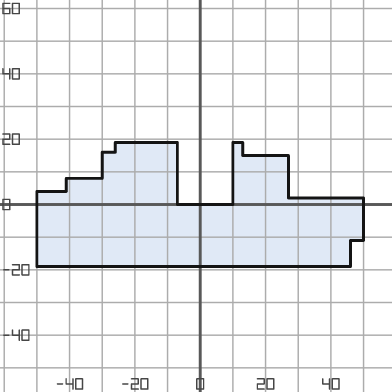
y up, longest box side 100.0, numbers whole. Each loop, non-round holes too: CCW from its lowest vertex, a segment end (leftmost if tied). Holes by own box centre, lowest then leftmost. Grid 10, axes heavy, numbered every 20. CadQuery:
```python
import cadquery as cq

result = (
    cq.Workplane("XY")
    .moveTo(-50.0, -19.0)
    .lineTo(46.0, -19.0)
    .lineTo(46.0, -11.0)
    .lineTo(50.0, -11.0)
    .lineTo(50.0, 2.0)
    .lineTo(27.0, 2.0)
    .lineTo(27.0, 15.0)
    .lineTo(13.0, 15.0)
    .lineTo(13.0, 19.0)
    .lineTo(10.0, 19.0)
    .lineTo(10.0, 0.0)
    .lineTo(-7.0, 0.0)
    .lineTo(-7.0, 19.0)
    .lineTo(-26.0, 19.0)
    .lineTo(-26.0, 16.0)
    .lineTo(-30.0, 16.0)
    .lineTo(-30.0, 8.0)
    .lineTo(-41.0, 8.0)
    .lineTo(-41.0, 4.0)
    .lineTo(-50.0, 4.0)
    .close()
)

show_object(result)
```